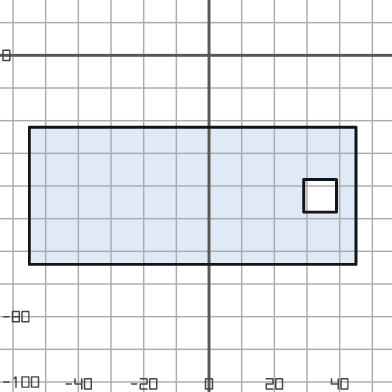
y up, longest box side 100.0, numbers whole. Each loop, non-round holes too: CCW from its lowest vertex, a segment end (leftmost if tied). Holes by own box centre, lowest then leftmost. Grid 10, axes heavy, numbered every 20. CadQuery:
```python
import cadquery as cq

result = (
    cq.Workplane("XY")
    .moveTo(-55.0, -64.0)
    .lineTo(45.0, -64.0)
    .lineTo(45.0, -22.0)
    .lineTo(-55.0, -22.0)
    .close()
    .moveTo(29.0, -48.0)
    .lineTo(39.0, -48.0)
    .lineTo(39.0, -38.0)
    .lineTo(29.0, -38.0)
    .close()
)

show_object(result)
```